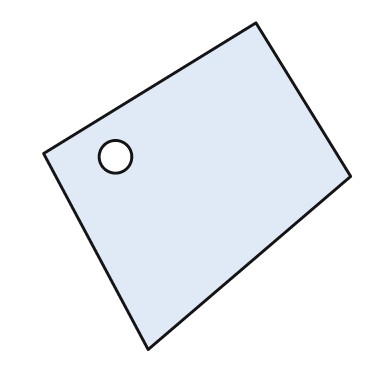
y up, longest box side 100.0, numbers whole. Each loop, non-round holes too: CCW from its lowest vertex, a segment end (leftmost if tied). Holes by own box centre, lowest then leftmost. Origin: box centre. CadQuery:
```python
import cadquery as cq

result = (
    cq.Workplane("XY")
    .moveTo(-15.0, -50.0)
    .lineTo(47.0, 3.0)
    .lineTo(18.0, 50.0)
    .lineTo(-47.0, 10.0)
    .close()
    .moveTo(-25.0, 9.0)
    .circle(5.0)
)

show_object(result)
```